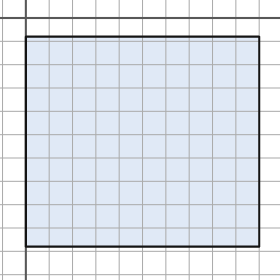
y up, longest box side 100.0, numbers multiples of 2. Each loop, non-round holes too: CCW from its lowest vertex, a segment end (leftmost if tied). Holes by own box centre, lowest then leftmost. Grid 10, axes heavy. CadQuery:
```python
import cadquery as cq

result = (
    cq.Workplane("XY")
    .moveTo(0.0, -98.0)
    .lineTo(100.0, -98.0)
    .lineTo(100.0, -8.0)
    .lineTo(0.0, -8.0)
    .close()
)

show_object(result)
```